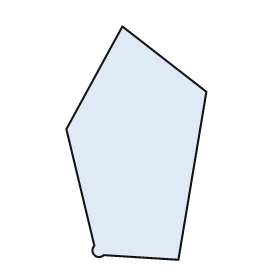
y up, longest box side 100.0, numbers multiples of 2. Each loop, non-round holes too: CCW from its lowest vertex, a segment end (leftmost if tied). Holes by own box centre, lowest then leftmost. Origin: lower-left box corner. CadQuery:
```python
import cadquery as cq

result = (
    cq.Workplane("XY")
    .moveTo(48.0, 0.0)
    .lineTo(60.0, 72.0)
    .lineTo(24.0, 100.0)
    .lineTo(0.0, 56.0)
    .lineTo(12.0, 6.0)
    .threePointArc((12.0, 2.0), (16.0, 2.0))
    .close()
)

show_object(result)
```